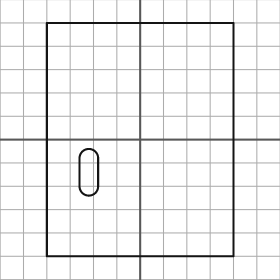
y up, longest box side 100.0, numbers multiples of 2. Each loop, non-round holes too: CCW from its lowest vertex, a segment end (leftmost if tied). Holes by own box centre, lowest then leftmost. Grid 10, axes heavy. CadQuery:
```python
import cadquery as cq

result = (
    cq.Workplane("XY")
    .moveTo(-40.0, -50.0)
    .lineTo(40.0, -50.0)
    .lineTo(40.0, 50.0)
    .lineTo(-40.0, 50.0)
    .close()
    .moveTo(-26.0, -20.0)
    .threePointArc((-22.0, -24.0), (-18.0, -20.0))
    .lineTo(-18.0, -8.0)
    .threePointArc((-22.0, -4.0), (-26.0, -8.0))
    .close()
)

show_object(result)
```